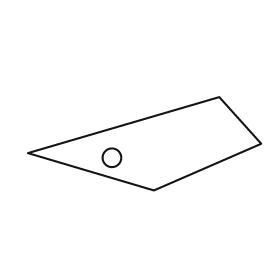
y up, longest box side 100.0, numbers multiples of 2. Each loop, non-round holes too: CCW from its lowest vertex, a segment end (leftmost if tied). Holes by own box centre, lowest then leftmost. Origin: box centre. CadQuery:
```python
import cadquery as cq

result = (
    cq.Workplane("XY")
    .moveTo(4.0, -20.0)
    .lineTo(50.0, 0.0)
    .lineTo(32.0, 20.0)
    .lineTo(-50.0, -4.0)
    .close()
    .moveTo(-14.0, -6.0)
    .circle(4.0)
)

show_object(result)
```